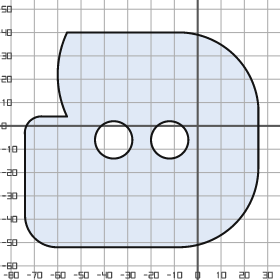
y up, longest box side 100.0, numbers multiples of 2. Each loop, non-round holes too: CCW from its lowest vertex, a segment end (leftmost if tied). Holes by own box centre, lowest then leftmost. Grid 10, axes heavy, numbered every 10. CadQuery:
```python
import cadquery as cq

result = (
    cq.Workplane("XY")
    .moveTo(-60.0, -52.0)
    .lineTo(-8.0, -52.0)
    .threePointArc((16.0, -42.0), (26.0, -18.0))
    .lineTo(26.0, 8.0)
    .threePointArc((16.0, 30.0), (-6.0, 40.0))
    .lineTo(-56.0, 40.0)
    .threePointArc((-60.0, 22.0), (-56.0, 4.0))
    .lineTo(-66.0, 4.0)
    .threePointArc((-72.0, 2.0), (-74.0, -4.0))
    .lineTo(-74.0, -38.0)
    .threePointArc((-70.0, -48.0), (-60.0, -52.0))
    .close()
    .moveTo(-36.0, -6.0)
    .circle(8.0)
    .moveTo(-12.0, -6.0)
    .circle(8.0)
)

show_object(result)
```